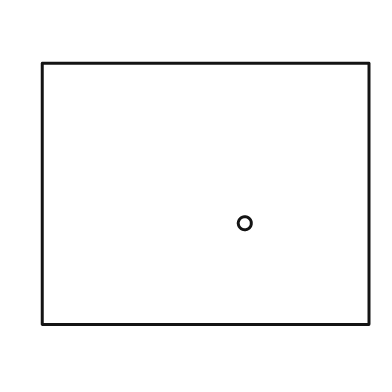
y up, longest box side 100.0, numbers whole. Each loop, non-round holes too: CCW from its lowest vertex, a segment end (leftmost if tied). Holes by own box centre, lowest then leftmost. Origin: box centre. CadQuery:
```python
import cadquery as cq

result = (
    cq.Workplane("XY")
    .moveTo(-50.0, -40.0)
    .lineTo(50.0, -40.0)
    .lineTo(50.0, 40.0)
    .lineTo(-50.0, 40.0)
    .close()
    .moveTo(12.0, -9.0)
    .circle(2.0)
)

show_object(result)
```